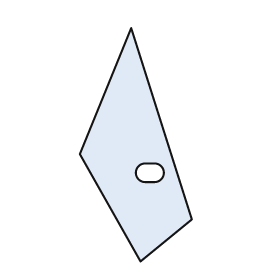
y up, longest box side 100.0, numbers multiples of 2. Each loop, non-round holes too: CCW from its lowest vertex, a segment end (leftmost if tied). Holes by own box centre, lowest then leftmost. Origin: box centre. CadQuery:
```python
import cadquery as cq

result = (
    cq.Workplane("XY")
    .moveTo(2.0, -50.0)
    .lineTo(24.0, -32.0)
    .lineTo(-2.0, 50.0)
    .lineTo(-24.0, -4.0)
    .close()
    .moveTo(4.0, -16.0)
    .lineTo(8.0, -16.0)
    .threePointArc((12.0, -12.0), (8.0, -8.0))
    .lineTo(4.0, -8.0)
    .threePointArc((0.0, -12.0), (4.0, -16.0))
    .close()
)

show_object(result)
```